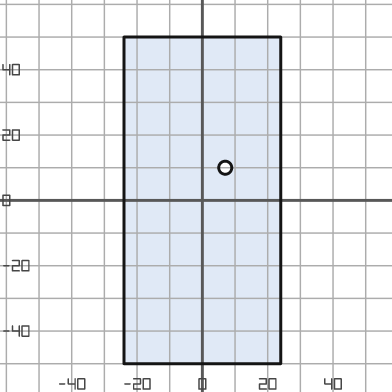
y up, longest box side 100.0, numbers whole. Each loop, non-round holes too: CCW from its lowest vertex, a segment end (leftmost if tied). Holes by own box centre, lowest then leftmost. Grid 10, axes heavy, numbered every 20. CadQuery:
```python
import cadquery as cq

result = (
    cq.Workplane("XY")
    .moveTo(-24.0, -50.0)
    .lineTo(24.0, -50.0)
    .lineTo(24.0, 50.0)
    .lineTo(-24.0, 50.0)
    .close()
    .moveTo(7.0, 10.0)
    .circle(2.0)
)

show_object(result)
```